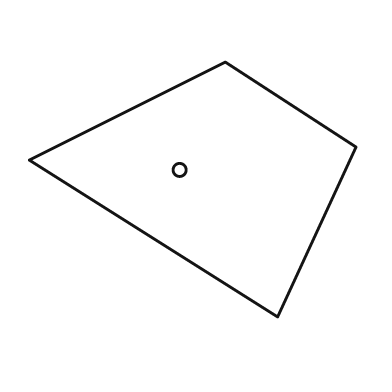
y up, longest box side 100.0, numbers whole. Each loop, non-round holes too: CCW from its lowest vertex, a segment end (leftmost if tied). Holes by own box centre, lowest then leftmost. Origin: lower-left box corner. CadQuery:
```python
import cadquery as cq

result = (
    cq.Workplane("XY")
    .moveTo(76.0, 0.0)
    .lineTo(100.0, 52.0)
    .lineTo(60.0, 78.0)
    .lineTo(0.0, 48.0)
    .close()
    .moveTo(46.0, 45.0)
    .circle(2.0)
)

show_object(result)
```